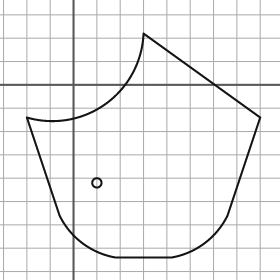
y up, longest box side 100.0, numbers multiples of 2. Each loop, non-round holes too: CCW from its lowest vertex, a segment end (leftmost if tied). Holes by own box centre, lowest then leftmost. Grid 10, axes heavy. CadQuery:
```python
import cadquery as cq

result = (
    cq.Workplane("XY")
    .moveTo(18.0, -74.0)
    .lineTo(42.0, -74.0)
    .threePointArc((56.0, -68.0), (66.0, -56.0))
    .lineTo(80.0, -14.0)
    .lineTo(30.0, 22.0)
    .threePointArc((14.0, -8.0), (-20.0, -14.0))
    .lineTo(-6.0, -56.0)
    .threePointArc((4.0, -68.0), (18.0, -74.0))
    .close()
    .moveTo(10.0, -42.0)
    .circle(2.0)
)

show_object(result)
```